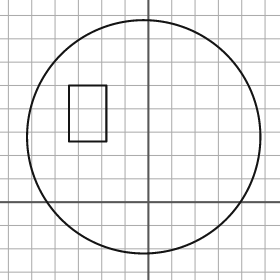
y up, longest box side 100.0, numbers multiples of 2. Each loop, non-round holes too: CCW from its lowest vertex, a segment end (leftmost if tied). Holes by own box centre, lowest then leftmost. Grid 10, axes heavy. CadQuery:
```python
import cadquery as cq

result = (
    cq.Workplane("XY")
    .moveTo(-2.0, 28.0)
    .circle(50.0)
    .moveTo(-34.0, 26.0)
    .lineTo(-18.0, 26.0)
    .lineTo(-18.0, 50.0)
    .lineTo(-34.0, 50.0)
    .close()
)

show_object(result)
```